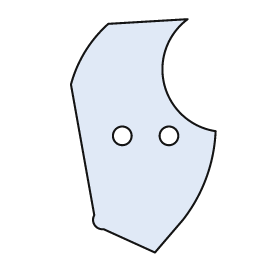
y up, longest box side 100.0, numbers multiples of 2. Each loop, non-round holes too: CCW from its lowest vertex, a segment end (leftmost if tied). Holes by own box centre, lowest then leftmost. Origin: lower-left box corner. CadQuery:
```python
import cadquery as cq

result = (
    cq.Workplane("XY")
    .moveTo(36.0, 0.0)
    .lineTo(48.0, 14.0)
    .threePointArc((58.0, 32.0), (62.0, 52.0))
    .threePointArc((40.0, 72.0), (50.0, 100.0))
    .lineTo(16.0, 98.0)
    .threePointArc((6.0, 86.0), (0.0, 72.0))
    .lineTo(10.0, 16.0)
    .threePointArc((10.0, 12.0), (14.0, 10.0))
    .close()
    .moveTo(22.0, 50.0)
    .circle(4.0)
    .moveTo(42.0, 50.0)
    .circle(4.0)
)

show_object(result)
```